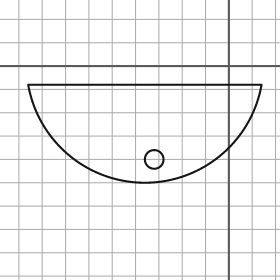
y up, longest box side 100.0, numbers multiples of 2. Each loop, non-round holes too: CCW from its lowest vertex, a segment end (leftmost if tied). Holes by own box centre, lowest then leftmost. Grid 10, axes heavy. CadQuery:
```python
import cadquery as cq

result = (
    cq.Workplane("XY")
    .moveTo(-86.0, -8.0)
    .threePointArc((-36.0, -50.0), (14.0, -8.0))
    .close()
    .moveTo(-32.0, -40.0)
    .circle(4.0)
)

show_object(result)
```